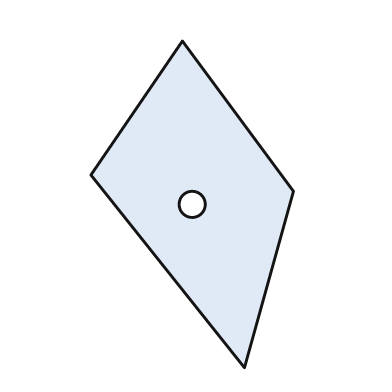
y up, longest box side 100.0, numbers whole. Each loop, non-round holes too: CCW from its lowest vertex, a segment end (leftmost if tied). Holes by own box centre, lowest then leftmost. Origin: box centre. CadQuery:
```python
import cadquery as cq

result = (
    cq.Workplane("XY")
    .moveTo(16.0, -50.0)
    .lineTo(31.0, 4.0)
    .lineTo(-3.0, 50.0)
    .lineTo(-31.0, 9.0)
    .close()
    .moveTo(0.0, 0.0)
    .circle(4.0)
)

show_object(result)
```